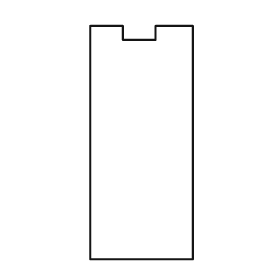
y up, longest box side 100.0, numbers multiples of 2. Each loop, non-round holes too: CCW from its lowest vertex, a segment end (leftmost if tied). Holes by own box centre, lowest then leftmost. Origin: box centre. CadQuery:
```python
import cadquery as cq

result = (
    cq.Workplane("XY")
    .moveTo(-22.0, -50.0)
    .lineTo(22.0, -50.0)
    .lineTo(22.0, 50.0)
    .lineTo(6.0, 50.0)
    .lineTo(6.0, 44.0)
    .lineTo(-8.0, 44.0)
    .lineTo(-8.0, 50.0)
    .lineTo(-22.0, 50.0)
    .close()
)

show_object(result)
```